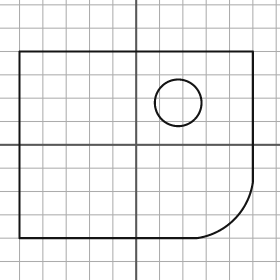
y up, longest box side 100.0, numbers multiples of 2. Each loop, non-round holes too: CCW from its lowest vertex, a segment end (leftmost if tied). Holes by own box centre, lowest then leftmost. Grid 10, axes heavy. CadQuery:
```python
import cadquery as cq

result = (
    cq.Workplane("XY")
    .moveTo(-50.0, -40.0)
    .lineTo(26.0, -40.0)
    .threePointArc((42.0, -32.0), (50.0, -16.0))
    .lineTo(50.0, 40.0)
    .lineTo(-50.0, 40.0)
    .close()
    .moveTo(18.0, 18.0)
    .circle(10.0)
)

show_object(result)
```